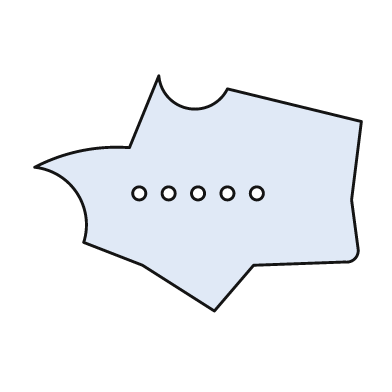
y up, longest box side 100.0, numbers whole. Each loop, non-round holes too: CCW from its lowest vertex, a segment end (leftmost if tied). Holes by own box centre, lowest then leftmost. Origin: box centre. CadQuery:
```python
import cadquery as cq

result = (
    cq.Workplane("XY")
    .moveTo(5.0, -36.0)
    .lineTo(17.0, -22.0)
    .lineTo(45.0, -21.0)
    .threePointArc((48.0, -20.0), (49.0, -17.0))
    .lineTo(47.0, -2.0)
    .lineTo(50.0, 22.0)
    .lineTo(9.0, 32.0)
    .threePointArc((-3.0, 26.0), (-12.0, 36.0))
    .lineTo(-21.0, 14.0)
    .threePointArc((-36.0, 13.0), (-50.0, 8.0))
    .threePointArc((-37.0, 0.0), (-35.0, -15.0))
    .lineTo(-17.0, -22.0)
    .close()
    .moveTo(-18.0, 0.0)
    .circle(2.0)
    .moveTo(-9.0, 0.0)
    .circle(2.0)
    .moveTo(0.0, 0.0)
    .circle(2.0)
    .moveTo(9.0, 0.0)
    .circle(2.0)
    .moveTo(18.0, 0.0)
    .circle(2.0)
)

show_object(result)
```